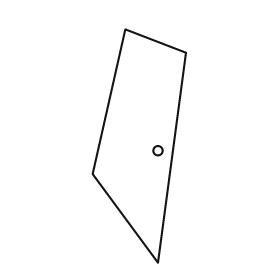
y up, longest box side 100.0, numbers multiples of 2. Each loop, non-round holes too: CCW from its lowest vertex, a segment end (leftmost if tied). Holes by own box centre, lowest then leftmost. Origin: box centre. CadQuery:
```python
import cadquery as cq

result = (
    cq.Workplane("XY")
    .moveTo(8.0, -50.0)
    .lineTo(20.0, 40.0)
    .lineTo(-6.0, 50.0)
    .lineTo(-20.0, -12.0)
    .close()
    .moveTo(8.0, -2.0)
    .circle(2.0)
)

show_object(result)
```